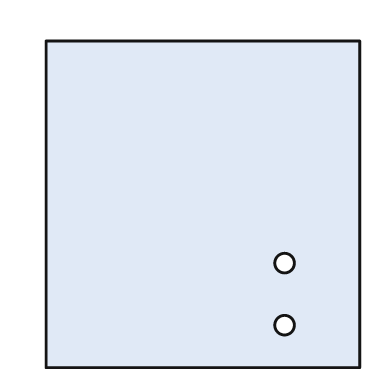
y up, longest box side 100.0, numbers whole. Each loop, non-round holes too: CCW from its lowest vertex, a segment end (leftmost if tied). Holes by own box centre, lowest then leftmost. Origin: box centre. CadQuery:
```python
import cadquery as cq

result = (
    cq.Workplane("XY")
    .moveTo(-48.0, -50.0)
    .lineTo(48.0, -50.0)
    .lineTo(48.0, 50.0)
    .lineTo(-48.0, 50.0)
    .close()
    .moveTo(25.0, -37.0)
    .circle(3.0)
    .moveTo(25.0, -18.0)
    .circle(3.0)
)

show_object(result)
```